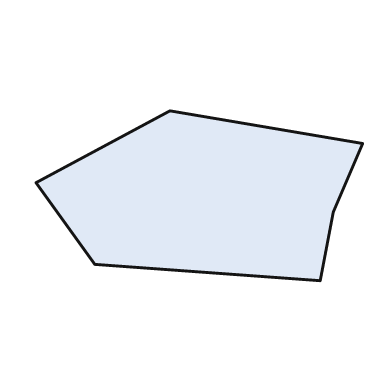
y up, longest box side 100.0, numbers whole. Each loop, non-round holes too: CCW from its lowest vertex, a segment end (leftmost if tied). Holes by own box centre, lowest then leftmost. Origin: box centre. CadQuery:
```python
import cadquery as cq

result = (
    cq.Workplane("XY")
    .moveTo(37.0, -26.0)
    .lineTo(41.0, -5.0)
    .lineTo(50.0, 16.0)
    .lineTo(-9.0, 26.0)
    .lineTo(-50.0, 4.0)
    .lineTo(-32.0, -21.0)
    .close()
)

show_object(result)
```